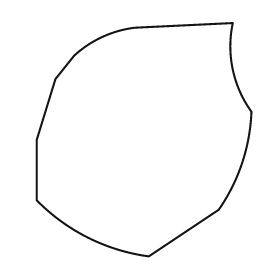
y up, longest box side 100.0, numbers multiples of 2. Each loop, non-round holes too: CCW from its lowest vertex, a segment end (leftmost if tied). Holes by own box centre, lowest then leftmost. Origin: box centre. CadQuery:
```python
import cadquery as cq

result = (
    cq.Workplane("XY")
    .moveTo(2.0, -50.0)
    .lineTo(32.0, -30.0)
    .threePointArc((42.0, -10.0), (46.0, 12.0))
    .threePointArc((38.0, 30.0), (38.0, 50.0))
    .lineTo(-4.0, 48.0)
    .threePointArc((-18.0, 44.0), (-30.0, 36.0))
    .lineTo(-38.0, 26.0)
    .lineTo(-46.0, 0.0)
    .lineTo(-46.0, -26.0)
    .threePointArc((-24.0, -42.0), (2.0, -50.0))
    .close()
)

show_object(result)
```